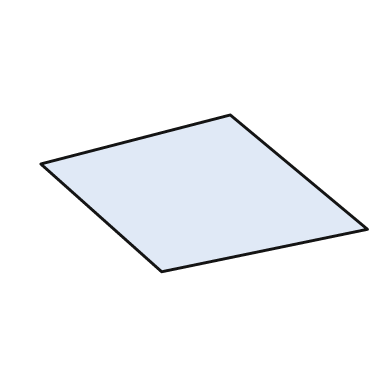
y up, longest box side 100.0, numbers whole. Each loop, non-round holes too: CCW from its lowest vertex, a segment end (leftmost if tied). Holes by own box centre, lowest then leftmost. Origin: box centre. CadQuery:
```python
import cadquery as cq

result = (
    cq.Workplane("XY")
    .moveTo(-13.0, -24.0)
    .lineTo(50.0, -11.0)
    .lineTo(8.0, 24.0)
    .lineTo(-50.0, 9.0)
    .close()
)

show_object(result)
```